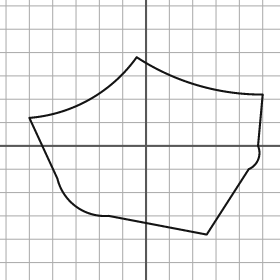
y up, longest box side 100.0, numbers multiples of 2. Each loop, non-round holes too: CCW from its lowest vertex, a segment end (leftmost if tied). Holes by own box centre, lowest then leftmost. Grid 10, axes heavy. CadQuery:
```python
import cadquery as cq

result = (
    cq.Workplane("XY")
    .moveTo(26.0, -38.0)
    .lineTo(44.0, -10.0)
    .threePointArc((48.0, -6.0), (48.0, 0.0))
    .lineTo(50.0, 22.0)
    .threePointArc((22.0, 26.0), (-4.0, 38.0))
    .threePointArc((-24.0, 20.0), (-50.0, 12.0))
    .lineTo(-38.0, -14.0)
    .threePointArc((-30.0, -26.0), (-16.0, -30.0))
    .close()
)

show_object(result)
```